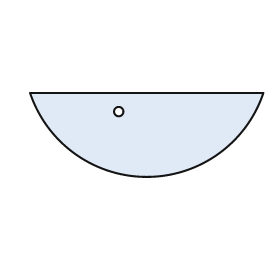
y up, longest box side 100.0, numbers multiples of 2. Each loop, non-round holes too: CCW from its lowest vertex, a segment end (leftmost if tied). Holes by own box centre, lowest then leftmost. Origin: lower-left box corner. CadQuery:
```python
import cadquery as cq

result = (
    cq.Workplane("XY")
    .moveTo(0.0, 36.0)
    .threePointArc((50.0, 0.0), (100.0, 36.0))
    .close()
    .moveTo(38.0, 28.0)
    .circle(2.0)
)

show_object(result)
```